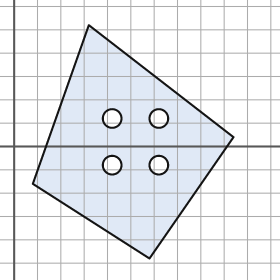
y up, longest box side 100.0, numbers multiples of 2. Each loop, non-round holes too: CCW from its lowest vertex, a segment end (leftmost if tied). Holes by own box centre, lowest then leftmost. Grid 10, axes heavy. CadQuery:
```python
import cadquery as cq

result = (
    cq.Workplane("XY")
    .moveTo(58.0, -48.0)
    .lineTo(94.0, 4.0)
    .lineTo(32.0, 52.0)
    .lineTo(8.0, -16.0)
    .close()
    .moveTo(42.0, -8.0)
    .circle(4.0)
    .moveTo(62.0, -8.0)
    .circle(4.0)
    .moveTo(42.0, 12.0)
    .circle(4.0)
    .moveTo(62.0, 12.0)
    .circle(4.0)
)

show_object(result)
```